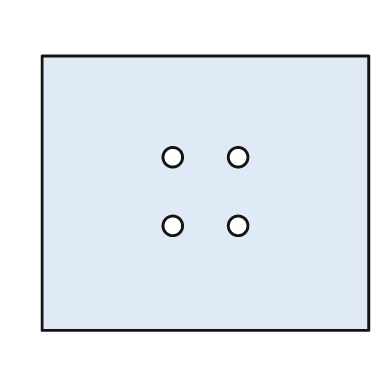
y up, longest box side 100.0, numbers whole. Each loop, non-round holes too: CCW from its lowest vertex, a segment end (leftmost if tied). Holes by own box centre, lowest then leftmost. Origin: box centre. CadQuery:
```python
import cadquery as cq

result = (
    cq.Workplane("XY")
    .moveTo(-50.0, -42.0)
    .lineTo(50.0, -42.0)
    .lineTo(50.0, 42.0)
    .lineTo(-50.0, 42.0)
    .close()
    .moveTo(-10.0, -10.0)
    .circle(3.0)
    .moveTo(10.0, -10.0)
    .circle(3.0)
    .moveTo(-10.0, 11.0)
    .circle(3.0)
    .moveTo(10.0, 11.0)
    .circle(3.0)
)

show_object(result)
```